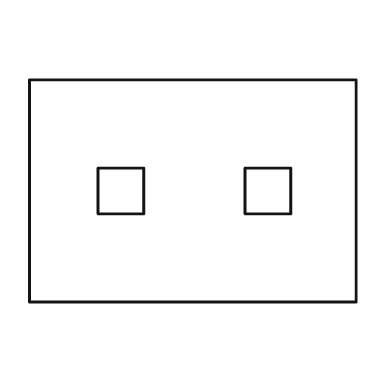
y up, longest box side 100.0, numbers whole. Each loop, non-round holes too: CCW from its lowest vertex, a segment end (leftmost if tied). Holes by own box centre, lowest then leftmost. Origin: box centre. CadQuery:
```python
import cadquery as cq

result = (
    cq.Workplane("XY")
    .moveTo(-50.0, -34.0)
    .lineTo(50.0, -34.0)
    .lineTo(50.0, 34.0)
    .lineTo(-50.0, 34.0)
    .close()
    .moveTo(-29.0, -7.0)
    .lineTo(-15.0, -7.0)
    .lineTo(-15.0, 7.0)
    .lineTo(-29.0, 7.0)
    .close()
    .moveTo(16.0, -7.0)
    .lineTo(30.0, -7.0)
    .lineTo(30.0, 7.0)
    .lineTo(16.0, 7.0)
    .close()
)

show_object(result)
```